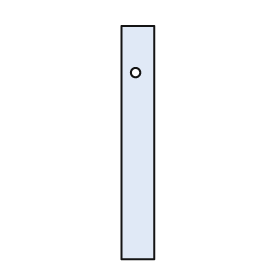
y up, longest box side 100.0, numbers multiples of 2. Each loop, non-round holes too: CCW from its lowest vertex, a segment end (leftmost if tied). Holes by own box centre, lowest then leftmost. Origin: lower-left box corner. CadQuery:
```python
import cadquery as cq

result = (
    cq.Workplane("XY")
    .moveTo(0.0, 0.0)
    .lineTo(14.0, 0.0)
    .lineTo(14.0, 100.0)
    .lineTo(0.0, 100.0)
    .close()
    .moveTo(6.0, 80.0)
    .circle(2.0)
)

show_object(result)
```